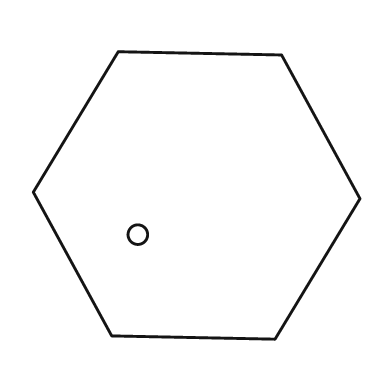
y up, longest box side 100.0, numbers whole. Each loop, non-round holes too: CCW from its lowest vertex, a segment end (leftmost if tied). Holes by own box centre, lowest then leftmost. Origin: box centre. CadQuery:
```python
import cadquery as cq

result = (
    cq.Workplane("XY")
    .moveTo(24.0, -44.0)
    .lineTo(50.0, -1.0)
    .lineTo(26.0, 43.0)
    .lineTo(-24.0, 44.0)
    .lineTo(-50.0, 1.0)
    .lineTo(-26.0, -43.0)
    .close()
    .moveTo(-18.0, -12.0)
    .circle(3.0)
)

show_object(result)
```